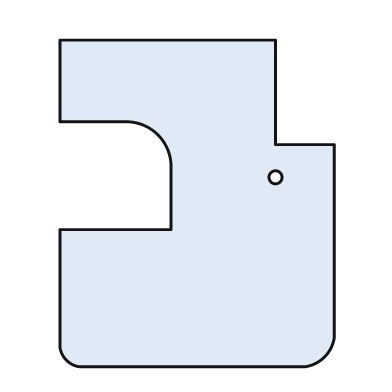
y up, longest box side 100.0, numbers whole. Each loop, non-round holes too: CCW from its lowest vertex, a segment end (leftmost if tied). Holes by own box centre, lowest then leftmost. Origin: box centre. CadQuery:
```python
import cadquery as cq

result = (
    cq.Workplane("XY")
    .moveTo(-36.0, -50.0)
    .lineTo(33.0, -50.0)
    .threePointArc((39.0, -47.0), (42.0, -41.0))
    .lineTo(42.0, 18.0)
    .lineTo(24.0, 18.0)
    .lineTo(24.0, 50.0)
    .lineTo(-42.0, 50.0)
    .lineTo(-42.0, 25.0)
    .lineTo(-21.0, 25.0)
    .threePointArc((-12.0, 21.0), (-8.0, 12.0))
    .lineTo(-8.0, -8.0)
    .lineTo(-42.0, -8.0)
    .lineTo(-42.0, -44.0)
    .threePointArc((-40.0, -48.0), (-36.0, -50.0))
    .close()
    .moveTo(24.0, 8.0)
    .circle(2.0)
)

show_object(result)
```